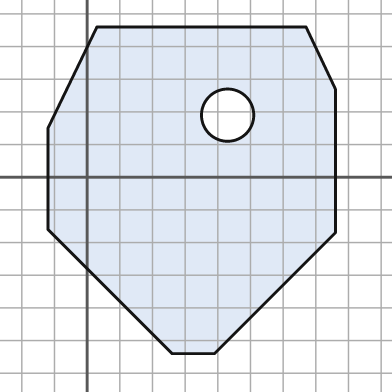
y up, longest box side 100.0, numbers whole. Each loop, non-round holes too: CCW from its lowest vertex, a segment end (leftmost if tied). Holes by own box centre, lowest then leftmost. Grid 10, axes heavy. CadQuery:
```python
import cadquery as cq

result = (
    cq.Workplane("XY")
    .moveTo(26.0, -54.0)
    .lineTo(39.0, -54.0)
    .lineTo(76.0, -17.0)
    .lineTo(76.0, 27.0)
    .lineTo(67.0, 46.0)
    .lineTo(3.0, 46.0)
    .lineTo(-12.0, 15.0)
    .lineTo(-12.0, -16.0)
    .close()
    .moveTo(43.0, 19.0)
    .circle(8.0)
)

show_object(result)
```